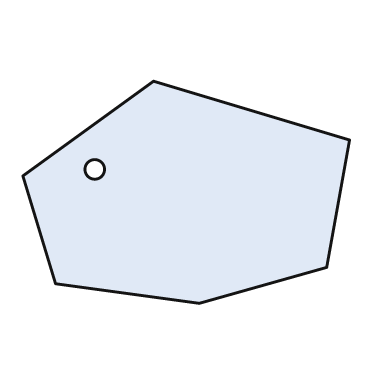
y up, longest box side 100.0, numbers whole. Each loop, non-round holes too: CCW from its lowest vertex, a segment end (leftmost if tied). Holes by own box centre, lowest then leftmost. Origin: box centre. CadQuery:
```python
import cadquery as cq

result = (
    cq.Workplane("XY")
    .moveTo(4.0, -34.0)
    .lineTo(43.0, -23.0)
    .lineTo(50.0, 16.0)
    .lineTo(-10.0, 34.0)
    .lineTo(-50.0, 5.0)
    .lineTo(-40.0, -28.0)
    .close()
    .moveTo(-28.0, 7.0)
    .circle(3.0)
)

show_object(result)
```